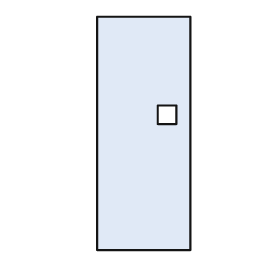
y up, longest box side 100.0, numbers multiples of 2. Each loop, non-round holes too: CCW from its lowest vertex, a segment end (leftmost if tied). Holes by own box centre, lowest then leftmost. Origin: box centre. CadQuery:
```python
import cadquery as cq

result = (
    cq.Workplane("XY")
    .moveTo(-20.0, -50.0)
    .lineTo(20.0, -50.0)
    .lineTo(20.0, 50.0)
    .lineTo(-20.0, 50.0)
    .close()
    .moveTo(6.0, 4.0)
    .lineTo(14.0, 4.0)
    .lineTo(14.0, 12.0)
    .lineTo(6.0, 12.0)
    .close()
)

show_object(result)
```